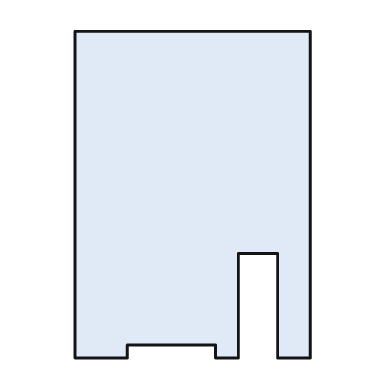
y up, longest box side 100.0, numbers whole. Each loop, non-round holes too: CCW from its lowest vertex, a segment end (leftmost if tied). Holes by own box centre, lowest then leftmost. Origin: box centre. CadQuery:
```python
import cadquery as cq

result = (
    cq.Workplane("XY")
    .moveTo(-36.0, -50.0)
    .lineTo(-20.0, -50.0)
    .lineTo(-20.0, -46.0)
    .lineTo(7.0, -46.0)
    .lineTo(7.0, -50.0)
    .lineTo(14.0, -50.0)
    .lineTo(14.0, -18.0)
    .lineTo(26.0, -18.0)
    .lineTo(26.0, -50.0)
    .lineTo(36.0, -50.0)
    .lineTo(36.0, 50.0)
    .lineTo(-36.0, 50.0)
    .close()
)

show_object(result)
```